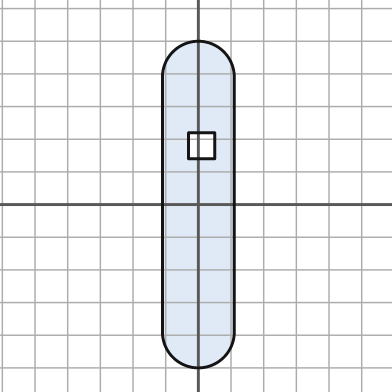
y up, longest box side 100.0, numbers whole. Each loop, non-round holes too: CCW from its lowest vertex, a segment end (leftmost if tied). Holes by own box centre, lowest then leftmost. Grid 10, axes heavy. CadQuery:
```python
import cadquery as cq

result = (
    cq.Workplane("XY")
    .moveTo(-11.0, -39.0)
    .threePointArc((0.0, -50.0), (11.0, -39.0))
    .lineTo(11.0, 39.0)
    .threePointArc((0.0, 50.0), (-11.0, 39.0))
    .close()
    .moveTo(-3.0, 14.0)
    .lineTo(5.0, 14.0)
    .lineTo(5.0, 22.0)
    .lineTo(-3.0, 22.0)
    .close()
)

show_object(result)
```